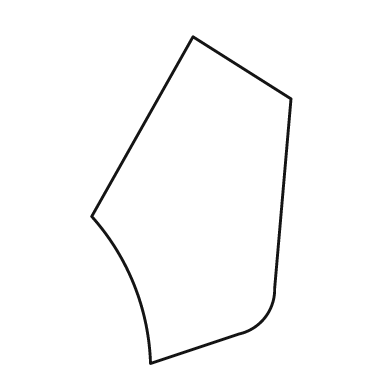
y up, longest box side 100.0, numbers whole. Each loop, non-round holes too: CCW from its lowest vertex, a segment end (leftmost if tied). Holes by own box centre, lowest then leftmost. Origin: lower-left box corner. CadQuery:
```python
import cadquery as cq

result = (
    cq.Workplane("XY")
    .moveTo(18.0, 0.0)
    .lineTo(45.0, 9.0)
    .threePointArc((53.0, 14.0), (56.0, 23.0))
    .lineTo(61.0, 81.0)
    .lineTo(31.0, 100.0)
    .lineTo(0.0, 45.0)
    .threePointArc((13.0, 24.0), (18.0, 0.0))
    .close()
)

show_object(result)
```